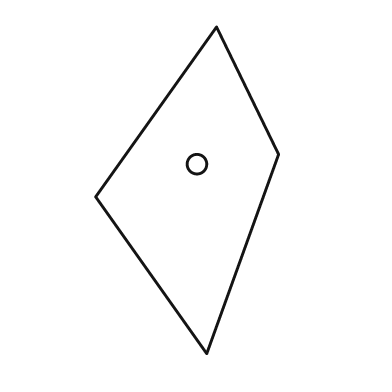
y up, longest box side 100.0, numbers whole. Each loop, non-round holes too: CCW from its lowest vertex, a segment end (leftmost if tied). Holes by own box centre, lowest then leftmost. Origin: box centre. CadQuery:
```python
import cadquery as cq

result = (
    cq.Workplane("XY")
    .moveTo(6.0, -50.0)
    .lineTo(28.0, 11.0)
    .lineTo(9.0, 50.0)
    .lineTo(-28.0, -2.0)
    .close()
    .moveTo(3.0, 8.0)
    .circle(3.0)
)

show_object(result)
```